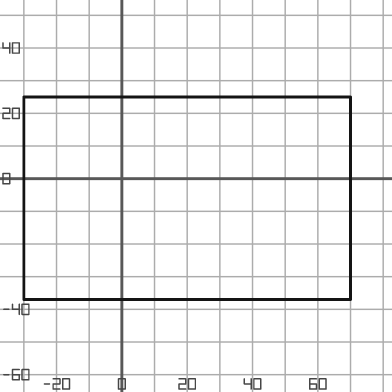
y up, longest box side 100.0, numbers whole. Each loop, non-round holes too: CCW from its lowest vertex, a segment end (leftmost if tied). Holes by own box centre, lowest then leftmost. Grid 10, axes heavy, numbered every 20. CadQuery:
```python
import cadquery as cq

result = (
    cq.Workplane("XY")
    .moveTo(-30.0, -37.0)
    .lineTo(70.0, -37.0)
    .lineTo(70.0, 25.0)
    .lineTo(-30.0, 25.0)
    .close()
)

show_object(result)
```